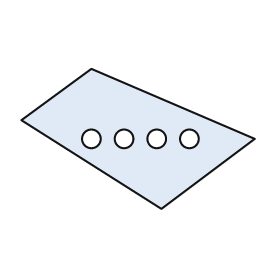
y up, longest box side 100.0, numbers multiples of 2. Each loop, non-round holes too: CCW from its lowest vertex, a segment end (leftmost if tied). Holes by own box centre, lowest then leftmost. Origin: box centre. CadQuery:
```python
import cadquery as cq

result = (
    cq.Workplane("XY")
    .moveTo(10.0, -30.0)
    .lineTo(50.0, 0.0)
    .lineTo(-20.0, 30.0)
    .lineTo(-50.0, 8.0)
    .close()
    .moveTo(-20.0, 0.0)
    .circle(4.0)
    .moveTo(-6.0, 0.0)
    .circle(4.0)
    .moveTo(8.0, 0.0)
    .circle(4.0)
    .moveTo(22.0, 0.0)
    .circle(4.0)
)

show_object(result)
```